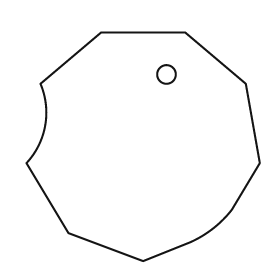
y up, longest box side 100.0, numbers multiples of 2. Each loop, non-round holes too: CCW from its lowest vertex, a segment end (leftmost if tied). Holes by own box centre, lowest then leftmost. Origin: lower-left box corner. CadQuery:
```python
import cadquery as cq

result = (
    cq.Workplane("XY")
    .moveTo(50.0, 0.0)
    .lineTo(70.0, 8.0)
    .threePointArc((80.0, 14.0), (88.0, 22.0))
    .lineTo(100.0, 42.0)
    .lineTo(94.0, 76.0)
    .lineTo(68.0, 98.0)
    .lineTo(32.0, 98.0)
    .lineTo(6.0, 76.0)
    .threePointArc((8.0, 58.0), (0.0, 42.0))
    .lineTo(18.0, 12.0)
    .close()
    .moveTo(60.0, 80.0)
    .circle(4.0)
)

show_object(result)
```